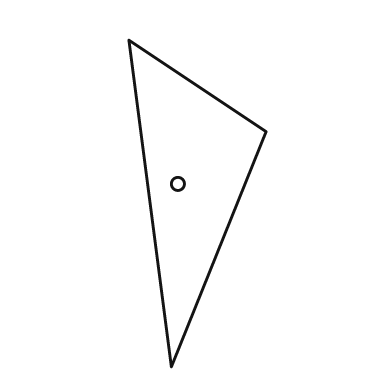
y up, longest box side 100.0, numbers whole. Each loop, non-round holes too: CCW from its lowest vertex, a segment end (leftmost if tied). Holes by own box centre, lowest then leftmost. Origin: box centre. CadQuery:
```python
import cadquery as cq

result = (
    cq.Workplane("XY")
    .moveTo(-8.0, -50.0)
    .lineTo(21.0, 22.0)
    .lineTo(-21.0, 50.0)
    .close()
    .moveTo(-6.0, 6.0)
    .circle(2.0)
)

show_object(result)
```